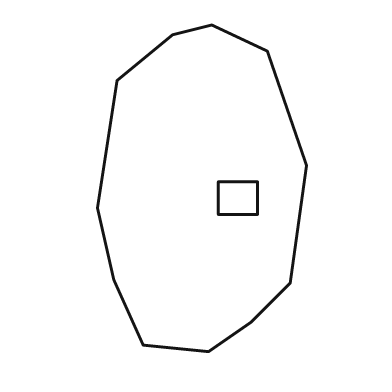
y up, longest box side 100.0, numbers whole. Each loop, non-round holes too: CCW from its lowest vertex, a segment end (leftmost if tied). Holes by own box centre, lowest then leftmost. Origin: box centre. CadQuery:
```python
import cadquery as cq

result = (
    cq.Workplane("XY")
    .moveTo(2.0, -50.0)
    .lineTo(15.0, -41.0)
    .lineTo(27.0, -29.0)
    .lineTo(32.0, 7.0)
    .lineTo(20.0, 42.0)
    .lineTo(3.0, 50.0)
    .lineTo(-9.0, 47.0)
    .lineTo(-26.0, 33.0)
    .lineTo(-32.0, -6.0)
    .lineTo(-27.0, -28.0)
    .lineTo(-18.0, -48.0)
    .close()
    .moveTo(5.0, -8.0)
    .lineTo(17.0, -8.0)
    .lineTo(17.0, 2.0)
    .lineTo(5.0, 2.0)
    .close()
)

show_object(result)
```